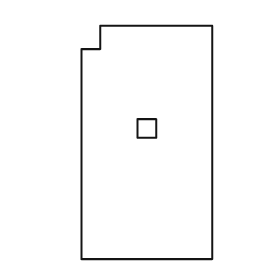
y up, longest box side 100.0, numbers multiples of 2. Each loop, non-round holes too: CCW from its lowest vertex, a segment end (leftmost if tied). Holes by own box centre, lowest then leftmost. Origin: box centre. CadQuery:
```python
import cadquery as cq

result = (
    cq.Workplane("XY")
    .moveTo(-28.0, -50.0)
    .lineTo(28.0, -50.0)
    .lineTo(28.0, 50.0)
    .lineTo(-20.0, 50.0)
    .lineTo(-20.0, 40.0)
    .lineTo(-28.0, 40.0)
    .close()
    .moveTo(-4.0, 2.0)
    .lineTo(4.0, 2.0)
    .lineTo(4.0, 10.0)
    .lineTo(-4.0, 10.0)
    .close()
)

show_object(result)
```